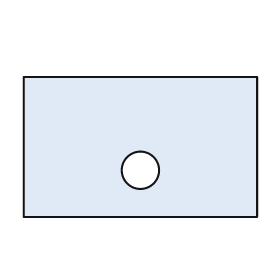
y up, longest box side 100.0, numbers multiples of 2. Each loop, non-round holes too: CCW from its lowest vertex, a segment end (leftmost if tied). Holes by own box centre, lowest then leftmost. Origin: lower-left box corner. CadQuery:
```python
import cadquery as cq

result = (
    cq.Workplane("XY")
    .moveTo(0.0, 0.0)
    .lineTo(100.0, 0.0)
    .lineTo(100.0, 60.0)
    .lineTo(0.0, 60.0)
    .close()
    .moveTo(50.0, 20.0)
    .circle(8.0)
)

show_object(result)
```